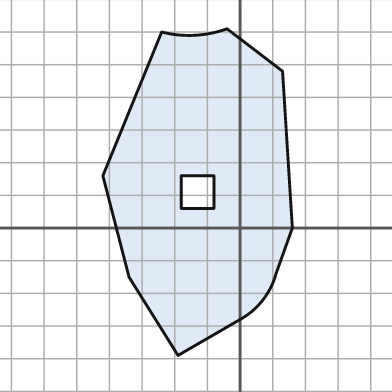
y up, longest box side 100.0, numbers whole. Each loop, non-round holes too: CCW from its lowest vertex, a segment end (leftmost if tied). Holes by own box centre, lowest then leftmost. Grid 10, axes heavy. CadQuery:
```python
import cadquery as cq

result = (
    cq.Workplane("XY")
    .moveTo(-19.0, -39.0)
    .lineTo(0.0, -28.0)
    .threePointArc((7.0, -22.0), (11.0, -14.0))
    .lineTo(16.0, 0.0)
    .lineTo(13.0, 48.0)
    .lineTo(-4.0, 61.0)
    .threePointArc((-14.0, 59.0), (-24.0, 60.0))
    .lineTo(-42.0, 16.0)
    .lineTo(-34.0, -15.0)
    .close()
    .moveTo(-18.0, 6.0)
    .lineTo(-8.0, 6.0)
    .lineTo(-8.0, 16.0)
    .lineTo(-18.0, 16.0)
    .close()
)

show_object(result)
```